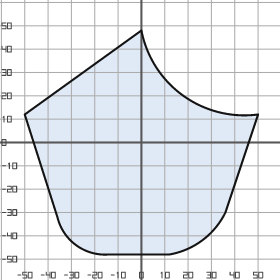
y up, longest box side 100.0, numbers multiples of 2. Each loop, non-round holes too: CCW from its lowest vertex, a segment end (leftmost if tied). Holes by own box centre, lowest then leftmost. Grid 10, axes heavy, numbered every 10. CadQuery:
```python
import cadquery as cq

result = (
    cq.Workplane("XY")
    .moveTo(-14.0, -48.0)
    .lineTo(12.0, -48.0)
    .threePointArc((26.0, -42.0), (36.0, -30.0))
    .lineTo(50.0, 12.0)
    .threePointArc((18.0, 20.0), (0.0, 48.0))
    .lineTo(-50.0, 12.0)
    .lineTo(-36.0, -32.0)
    .threePointArc((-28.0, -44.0), (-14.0, -48.0))
    .close()
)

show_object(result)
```